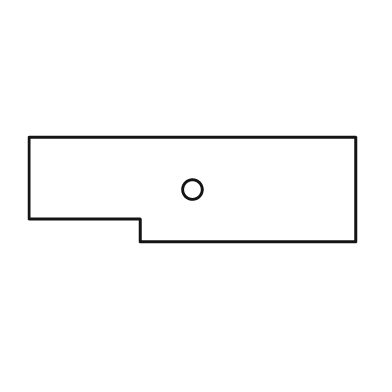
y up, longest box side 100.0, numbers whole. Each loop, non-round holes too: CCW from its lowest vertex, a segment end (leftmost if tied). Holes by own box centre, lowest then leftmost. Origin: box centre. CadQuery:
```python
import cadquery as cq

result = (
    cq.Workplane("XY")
    .moveTo(-16.0, -16.0)
    .lineTo(50.0, -16.0)
    .lineTo(50.0, 16.0)
    .lineTo(-50.0, 16.0)
    .lineTo(-50.0, -9.0)
    .lineTo(-16.0, -9.0)
    .close()
    .moveTo(0.0, 0.0)
    .circle(3.0)
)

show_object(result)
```